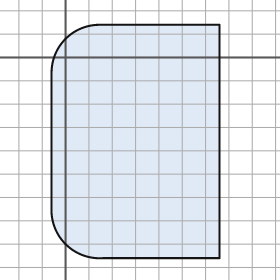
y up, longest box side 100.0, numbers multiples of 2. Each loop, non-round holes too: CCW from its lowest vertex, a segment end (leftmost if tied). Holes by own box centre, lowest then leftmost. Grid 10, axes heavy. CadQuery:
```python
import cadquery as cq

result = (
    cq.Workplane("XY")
    .moveTo(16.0, -86.0)
    .lineTo(66.0, -86.0)
    .lineTo(66.0, 14.0)
    .lineTo(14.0, 14.0)
    .threePointArc((0.0, 8.0), (-6.0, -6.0))
    .lineTo(-6.0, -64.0)
    .threePointArc((0.0, -80.0), (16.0, -86.0))
    .close()
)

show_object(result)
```